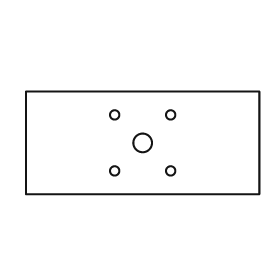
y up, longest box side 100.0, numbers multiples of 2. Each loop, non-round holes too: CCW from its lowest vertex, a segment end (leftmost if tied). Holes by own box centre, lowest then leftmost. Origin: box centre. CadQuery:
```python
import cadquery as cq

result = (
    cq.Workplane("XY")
    .moveTo(-50.0, -22.0)
    .lineTo(50.0, -22.0)
    .lineTo(50.0, 22.0)
    .lineTo(-50.0, 22.0)
    .close()
    .moveTo(-12.0, -12.0)
    .circle(2.0)
    .moveTo(12.0, -12.0)
    .circle(2.0)
    .moveTo(0.0, 0.0)
    .circle(4.0)
    .moveTo(-12.0, 12.0)
    .circle(2.0)
    .moveTo(12.0, 12.0)
    .circle(2.0)
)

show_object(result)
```